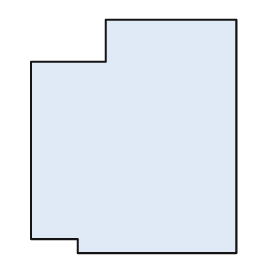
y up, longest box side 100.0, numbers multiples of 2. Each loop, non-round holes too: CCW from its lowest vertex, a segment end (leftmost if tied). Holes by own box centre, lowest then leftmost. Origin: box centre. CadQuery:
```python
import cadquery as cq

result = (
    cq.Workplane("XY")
    .moveTo(-24.0, -50.0)
    .lineTo(44.0, -50.0)
    .lineTo(44.0, 50.0)
    .lineTo(-12.0, 50.0)
    .lineTo(-12.0, 32.0)
    .lineTo(-44.0, 32.0)
    .lineTo(-44.0, -44.0)
    .lineTo(-24.0, -44.0)
    .close()
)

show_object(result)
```